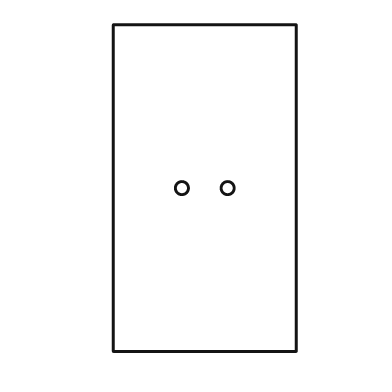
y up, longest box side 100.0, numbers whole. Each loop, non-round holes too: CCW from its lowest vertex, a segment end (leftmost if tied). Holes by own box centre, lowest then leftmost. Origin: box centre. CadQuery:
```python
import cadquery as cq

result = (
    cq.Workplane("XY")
    .moveTo(-28.0, -50.0)
    .lineTo(28.0, -50.0)
    .lineTo(28.0, 50.0)
    .lineTo(-28.0, 50.0)
    .close()
    .moveTo(-7.0, 0.0)
    .circle(2.0)
    .moveTo(7.0, 0.0)
    .circle(2.0)
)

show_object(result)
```